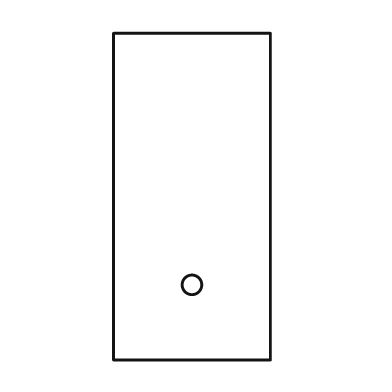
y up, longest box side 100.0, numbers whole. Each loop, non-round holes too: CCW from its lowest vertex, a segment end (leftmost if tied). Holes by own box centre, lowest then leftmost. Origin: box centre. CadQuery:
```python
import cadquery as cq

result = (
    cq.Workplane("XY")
    .moveTo(-24.0, -50.0)
    .lineTo(24.0, -50.0)
    .lineTo(24.0, 50.0)
    .lineTo(-24.0, 50.0)
    .close()
    .moveTo(0.0, -27.0)
    .circle(3.0)
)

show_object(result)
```